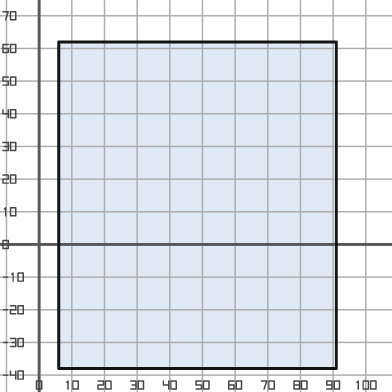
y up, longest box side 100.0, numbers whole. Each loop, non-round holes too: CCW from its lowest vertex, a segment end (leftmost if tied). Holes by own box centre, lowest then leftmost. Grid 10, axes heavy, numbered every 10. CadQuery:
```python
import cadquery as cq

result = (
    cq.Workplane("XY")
    .moveTo(6.0, -38.0)
    .lineTo(91.0, -38.0)
    .lineTo(91.0, 62.0)
    .lineTo(6.0, 62.0)
    .close()
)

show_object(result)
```